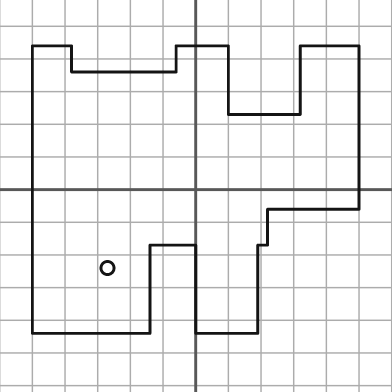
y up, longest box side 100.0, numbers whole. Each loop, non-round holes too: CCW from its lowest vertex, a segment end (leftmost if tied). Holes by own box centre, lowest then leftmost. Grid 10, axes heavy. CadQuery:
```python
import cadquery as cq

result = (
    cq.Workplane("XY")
    .moveTo(-50.0, -44.0)
    .lineTo(-14.0, -44.0)
    .lineTo(-14.0, -17.0)
    .lineTo(0.0, -17.0)
    .lineTo(0.0, -44.0)
    .lineTo(19.0, -44.0)
    .lineTo(19.0, -17.0)
    .lineTo(22.0, -17.0)
    .lineTo(22.0, -6.0)
    .lineTo(50.0, -6.0)
    .lineTo(50.0, 44.0)
    .lineTo(32.0, 44.0)
    .lineTo(32.0, 23.0)
    .lineTo(10.0, 23.0)
    .lineTo(10.0, 44.0)
    .lineTo(-6.0, 44.0)
    .lineTo(-6.0, 36.0)
    .lineTo(-38.0, 36.0)
    .lineTo(-38.0, 44.0)
    .lineTo(-50.0, 44.0)
    .close()
    .moveTo(-27.0, -24.0)
    .circle(2.0)
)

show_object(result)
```